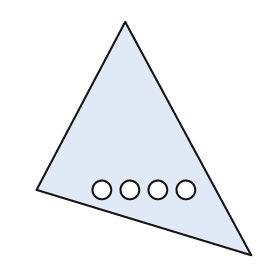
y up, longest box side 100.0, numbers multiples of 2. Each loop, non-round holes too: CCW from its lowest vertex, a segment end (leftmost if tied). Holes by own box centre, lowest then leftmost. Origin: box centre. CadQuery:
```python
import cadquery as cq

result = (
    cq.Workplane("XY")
    .moveTo(46.0, -50.0)
    .lineTo(-8.0, 50.0)
    .lineTo(-46.0, -22.0)
    .close()
    .moveTo(-18.0, -22.0)
    .circle(4.0)
    .moveTo(-6.0, -22.0)
    .circle(4.0)
    .moveTo(6.0, -22.0)
    .circle(4.0)
    .moveTo(18.0, -22.0)
    .circle(4.0)
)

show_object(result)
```